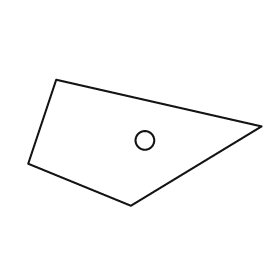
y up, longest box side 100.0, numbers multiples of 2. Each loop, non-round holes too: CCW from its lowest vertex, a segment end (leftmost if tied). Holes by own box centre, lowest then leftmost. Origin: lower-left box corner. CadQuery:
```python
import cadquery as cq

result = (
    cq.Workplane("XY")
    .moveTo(44.0, 0.0)
    .lineTo(100.0, 34.0)
    .lineTo(12.0, 54.0)
    .lineTo(0.0, 18.0)
    .close()
    .moveTo(50.0, 28.0)
    .circle(4.0)
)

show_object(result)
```